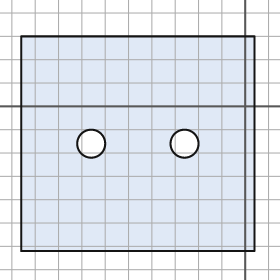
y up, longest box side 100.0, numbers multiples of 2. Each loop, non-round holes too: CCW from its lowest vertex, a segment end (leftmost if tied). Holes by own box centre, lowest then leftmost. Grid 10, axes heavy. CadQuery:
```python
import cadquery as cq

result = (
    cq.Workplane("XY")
    .moveTo(-96.0, -62.0)
    .lineTo(4.0, -62.0)
    .lineTo(4.0, 30.0)
    .lineTo(-96.0, 30.0)
    .close()
    .moveTo(-66.0, -16.0)
    .circle(6.0)
    .moveTo(-26.0, -16.0)
    .circle(6.0)
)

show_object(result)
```